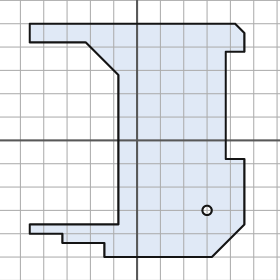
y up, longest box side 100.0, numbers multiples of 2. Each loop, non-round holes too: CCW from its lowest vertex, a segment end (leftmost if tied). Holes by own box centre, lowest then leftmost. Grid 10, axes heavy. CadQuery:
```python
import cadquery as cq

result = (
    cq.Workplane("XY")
    .moveTo(-14.0, -50.0)
    .lineTo(32.0, -50.0)
    .lineTo(46.0, -36.0)
    .lineTo(46.0, -8.0)
    .lineTo(38.0, -8.0)
    .lineTo(38.0, 38.0)
    .lineTo(46.0, 38.0)
    .lineTo(46.0, 46.0)
    .lineTo(42.0, 50.0)
    .lineTo(-46.0, 50.0)
    .lineTo(-46.0, 42.0)
    .lineTo(-22.0, 42.0)
    .lineTo(-8.0, 28.0)
    .lineTo(-8.0, -36.0)
    .lineTo(-46.0, -36.0)
    .lineTo(-46.0, -40.0)
    .lineTo(-32.0, -40.0)
    .lineTo(-32.0, -44.0)
    .lineTo(-14.0, -44.0)
    .close()
    .moveTo(30.0, -30.0)
    .circle(2.0)
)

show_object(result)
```